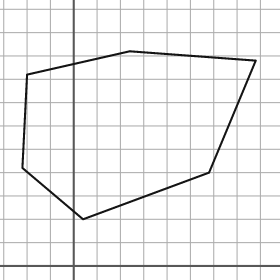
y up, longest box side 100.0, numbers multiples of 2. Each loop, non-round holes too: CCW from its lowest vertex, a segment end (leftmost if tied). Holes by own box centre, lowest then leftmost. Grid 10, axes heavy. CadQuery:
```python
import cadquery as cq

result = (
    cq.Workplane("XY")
    .moveTo(4.0, 20.0)
    .lineTo(58.0, 40.0)
    .lineTo(78.0, 88.0)
    .lineTo(24.0, 92.0)
    .lineTo(-20.0, 82.0)
    .lineTo(-22.0, 42.0)
    .close()
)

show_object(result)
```